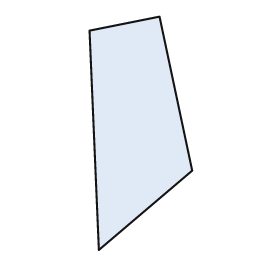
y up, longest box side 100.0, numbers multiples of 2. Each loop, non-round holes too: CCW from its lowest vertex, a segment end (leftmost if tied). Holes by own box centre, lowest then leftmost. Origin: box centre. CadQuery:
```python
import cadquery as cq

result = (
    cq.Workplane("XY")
    .moveTo(-18.0, -50.0)
    .lineTo(22.0, -16.0)
    .lineTo(8.0, 50.0)
    .lineTo(-22.0, 44.0)
    .close()
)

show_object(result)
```